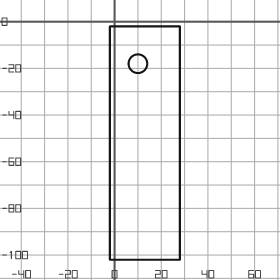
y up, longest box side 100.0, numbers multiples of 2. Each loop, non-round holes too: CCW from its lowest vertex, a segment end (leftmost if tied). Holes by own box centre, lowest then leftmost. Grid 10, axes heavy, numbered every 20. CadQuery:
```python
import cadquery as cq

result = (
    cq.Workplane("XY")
    .moveTo(-2.0, -102.0)
    .lineTo(28.0, -102.0)
    .lineTo(28.0, -2.0)
    .lineTo(-2.0, -2.0)
    .close()
    .moveTo(10.0, -18.0)
    .circle(4.0)
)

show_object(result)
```